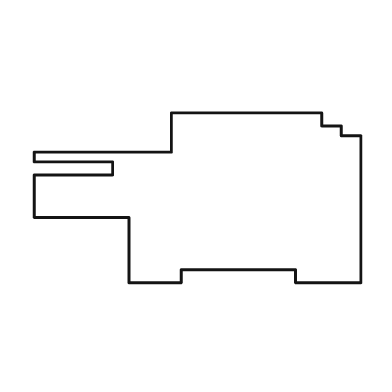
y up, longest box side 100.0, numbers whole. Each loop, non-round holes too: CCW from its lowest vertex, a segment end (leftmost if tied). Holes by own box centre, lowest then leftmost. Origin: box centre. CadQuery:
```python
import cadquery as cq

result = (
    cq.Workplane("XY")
    .moveTo(-21.0, -26.0)
    .lineTo(-5.0, -26.0)
    .lineTo(-5.0, -22.0)
    .lineTo(30.0, -22.0)
    .lineTo(30.0, -26.0)
    .lineTo(50.0, -26.0)
    .lineTo(50.0, 19.0)
    .lineTo(44.0, 19.0)
    .lineTo(44.0, 22.0)
    .lineTo(38.0, 22.0)
    .lineTo(38.0, 26.0)
    .lineTo(-8.0, 26.0)
    .lineTo(-8.0, 14.0)
    .lineTo(-50.0, 14.0)
    .lineTo(-50.0, 11.0)
    .lineTo(-26.0, 11.0)
    .lineTo(-26.0, 7.0)
    .lineTo(-50.0, 7.0)
    .lineTo(-50.0, -6.0)
    .lineTo(-21.0, -6.0)
    .close()
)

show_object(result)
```